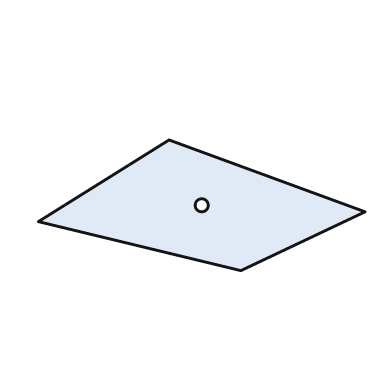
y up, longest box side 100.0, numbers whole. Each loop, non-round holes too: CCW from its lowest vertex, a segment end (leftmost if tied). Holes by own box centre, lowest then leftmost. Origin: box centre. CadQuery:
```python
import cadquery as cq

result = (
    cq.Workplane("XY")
    .moveTo(12.0, -20.0)
    .lineTo(50.0, -2.0)
    .lineTo(-10.0, 20.0)
    .lineTo(-50.0, -5.0)
    .close()
    .moveTo(0.0, 0.0)
    .circle(2.0)
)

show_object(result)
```